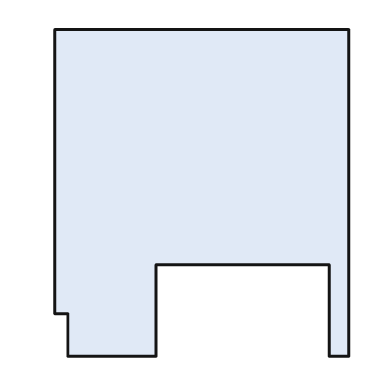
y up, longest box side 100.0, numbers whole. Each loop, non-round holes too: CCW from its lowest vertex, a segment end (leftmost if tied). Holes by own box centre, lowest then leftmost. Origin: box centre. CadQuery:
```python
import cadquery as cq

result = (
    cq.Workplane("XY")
    .moveTo(-41.0, -50.0)
    .lineTo(-14.0, -50.0)
    .lineTo(-14.0, -22.0)
    .lineTo(39.0, -22.0)
    .lineTo(39.0, -50.0)
    .lineTo(45.0, -50.0)
    .lineTo(45.0, 50.0)
    .lineTo(-45.0, 50.0)
    .lineTo(-45.0, -37.0)
    .lineTo(-41.0, -37.0)
    .close()
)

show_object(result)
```